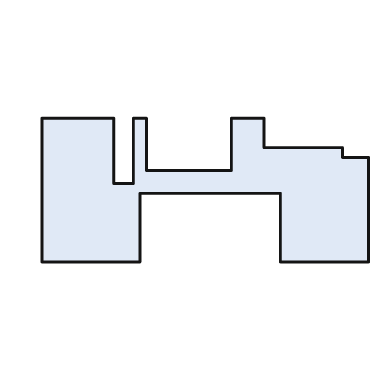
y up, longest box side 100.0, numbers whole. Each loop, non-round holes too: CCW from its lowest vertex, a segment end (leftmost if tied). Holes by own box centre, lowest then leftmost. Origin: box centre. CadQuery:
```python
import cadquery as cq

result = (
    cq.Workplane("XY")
    .moveTo(-50.0, -22.0)
    .lineTo(-20.0, -22.0)
    .lineTo(-20.0, -1.0)
    .lineTo(23.0, -1.0)
    .lineTo(23.0, -22.0)
    .lineTo(50.0, -22.0)
    .lineTo(50.0, 10.0)
    .lineTo(42.0, 10.0)
    .lineTo(42.0, 13.0)
    .lineTo(18.0, 13.0)
    .lineTo(18.0, 22.0)
    .lineTo(8.0, 22.0)
    .lineTo(8.0, 6.0)
    .lineTo(-18.0, 6.0)
    .lineTo(-18.0, 22.0)
    .lineTo(-22.0, 22.0)
    .lineTo(-22.0, 2.0)
    .lineTo(-28.0, 2.0)
    .lineTo(-28.0, 22.0)
    .lineTo(-50.0, 22.0)
    .close()
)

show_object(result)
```